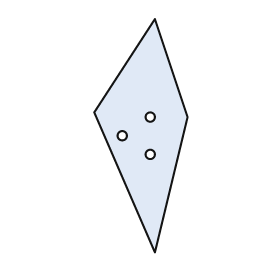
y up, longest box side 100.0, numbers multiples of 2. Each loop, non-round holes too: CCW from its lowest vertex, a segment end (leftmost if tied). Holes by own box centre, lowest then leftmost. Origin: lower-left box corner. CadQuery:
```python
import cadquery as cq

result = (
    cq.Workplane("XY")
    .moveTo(26.0, 0.0)
    .lineTo(40.0, 58.0)
    .lineTo(26.0, 100.0)
    .lineTo(0.0, 60.0)
    .close()
    .moveTo(24.0, 42.0)
    .circle(2.0)
    .moveTo(12.0, 50.0)
    .circle(2.0)
    .moveTo(24.0, 58.0)
    .circle(2.0)
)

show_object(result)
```